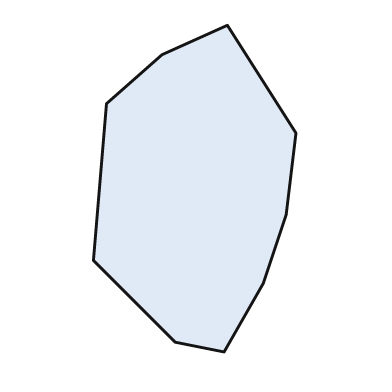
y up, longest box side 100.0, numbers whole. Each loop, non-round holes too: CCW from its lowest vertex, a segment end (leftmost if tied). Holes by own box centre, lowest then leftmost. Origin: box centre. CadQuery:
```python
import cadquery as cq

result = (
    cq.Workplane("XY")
    .moveTo(9.0, -50.0)
    .lineTo(21.0, -29.0)
    .lineTo(28.0, -8.0)
    .lineTo(31.0, 17.0)
    .lineTo(10.0, 50.0)
    .lineTo(-10.0, 41.0)
    .lineTo(-27.0, 26.0)
    .lineTo(-31.0, -22.0)
    .lineTo(-6.0, -47.0)
    .close()
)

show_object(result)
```